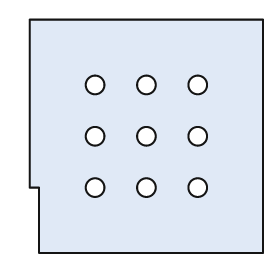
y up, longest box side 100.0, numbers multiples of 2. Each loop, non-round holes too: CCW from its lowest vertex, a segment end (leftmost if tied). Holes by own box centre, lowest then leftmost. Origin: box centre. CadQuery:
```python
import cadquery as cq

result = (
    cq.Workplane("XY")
    .moveTo(-46.0, -50.0)
    .lineTo(50.0, -50.0)
    .lineTo(50.0, 50.0)
    .lineTo(-50.0, 50.0)
    .lineTo(-50.0, -22.0)
    .lineTo(-46.0, -22.0)
    .close()
    .moveTo(-22.0, -22.0)
    .circle(4.0)
    .moveTo(0.0, -22.0)
    .circle(4.0)
    .moveTo(22.0, -22.0)
    .circle(4.0)
    .moveTo(-22.0, 0.0)
    .circle(4.0)
    .moveTo(0.0, 0.0)
    .circle(4.0)
    .moveTo(22.0, 0.0)
    .circle(4.0)
    .moveTo(-22.0, 22.0)
    .circle(4.0)
    .moveTo(0.0, 22.0)
    .circle(4.0)
    .moveTo(22.0, 22.0)
    .circle(4.0)
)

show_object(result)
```